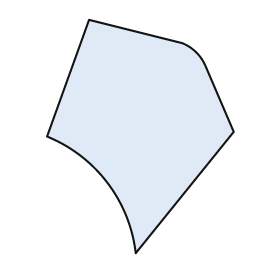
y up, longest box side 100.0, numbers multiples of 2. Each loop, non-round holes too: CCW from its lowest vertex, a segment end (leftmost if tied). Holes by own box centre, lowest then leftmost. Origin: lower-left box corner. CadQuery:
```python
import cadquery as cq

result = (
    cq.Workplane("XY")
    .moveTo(38.0, 0.0)
    .lineTo(80.0, 52.0)
    .lineTo(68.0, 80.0)
    .threePointArc((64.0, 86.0), (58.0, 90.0))
    .lineTo(18.0, 100.0)
    .lineTo(0.0, 50.0)
    .threePointArc((26.0, 30.0), (38.0, 0.0))
    .close()
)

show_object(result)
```